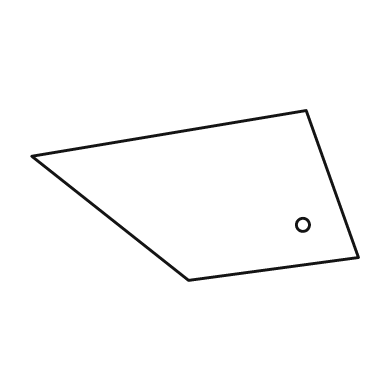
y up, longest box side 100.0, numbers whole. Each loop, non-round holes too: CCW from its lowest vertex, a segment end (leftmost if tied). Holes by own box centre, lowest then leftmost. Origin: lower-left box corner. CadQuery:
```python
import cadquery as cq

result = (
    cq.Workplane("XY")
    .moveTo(48.0, 0.0)
    .lineTo(100.0, 7.0)
    .lineTo(84.0, 52.0)
    .lineTo(0.0, 38.0)
    .close()
    .moveTo(83.0, 17.0)
    .circle(2.0)
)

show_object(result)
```